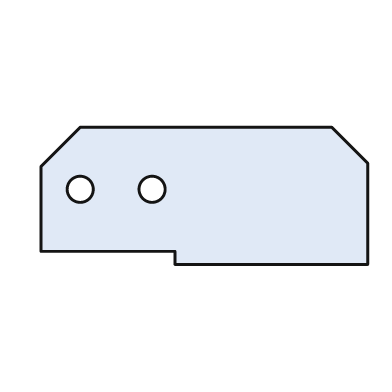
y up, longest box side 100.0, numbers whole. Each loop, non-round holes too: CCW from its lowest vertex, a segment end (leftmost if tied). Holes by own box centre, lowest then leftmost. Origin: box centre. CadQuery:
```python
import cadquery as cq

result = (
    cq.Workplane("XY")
    .moveTo(-9.0, -21.0)
    .lineTo(50.0, -21.0)
    .lineTo(50.0, 10.0)
    .lineTo(39.0, 21.0)
    .lineTo(-38.0, 21.0)
    .lineTo(-50.0, 9.0)
    .lineTo(-50.0, -17.0)
    .lineTo(-9.0, -17.0)
    .close()
    .moveTo(-38.0, 2.0)
    .circle(4.0)
    .moveTo(-16.0, 2.0)
    .circle(4.0)
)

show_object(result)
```